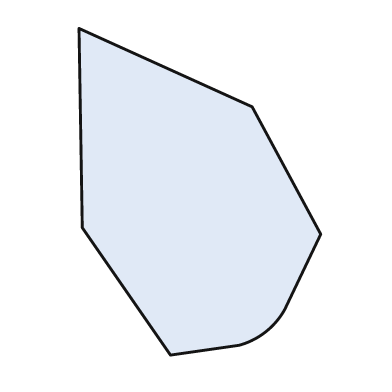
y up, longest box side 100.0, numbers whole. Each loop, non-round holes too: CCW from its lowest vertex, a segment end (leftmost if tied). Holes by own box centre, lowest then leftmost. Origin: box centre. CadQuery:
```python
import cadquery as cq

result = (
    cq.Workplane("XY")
    .moveTo(-9.0, -50.0)
    .lineTo(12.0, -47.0)
    .threePointArc((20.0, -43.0), (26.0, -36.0))
    .lineTo(37.0, -13.0)
    .lineTo(16.0, 26.0)
    .lineTo(-37.0, 50.0)
    .lineTo(-36.0, -11.0)
    .close()
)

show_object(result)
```